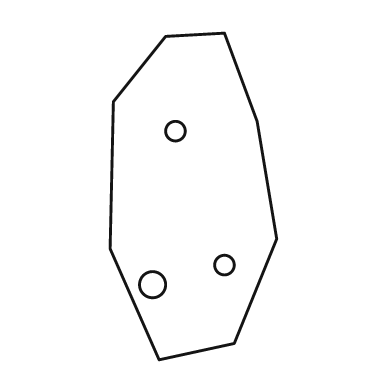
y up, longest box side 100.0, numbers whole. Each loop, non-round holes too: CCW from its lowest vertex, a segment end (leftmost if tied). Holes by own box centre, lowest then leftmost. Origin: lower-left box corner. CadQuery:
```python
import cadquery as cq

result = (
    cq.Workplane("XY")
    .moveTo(15.0, 0.0)
    .lineTo(38.0, 5.0)
    .lineTo(51.0, 37.0)
    .lineTo(45.0, 73.0)
    .lineTo(35.0, 100.0)
    .lineTo(17.0, 99.0)
    .lineTo(1.0, 79.0)
    .lineTo(0.0, 34.0)
    .close()
    .moveTo(13.0, 23.0)
    .circle(4.0)
    .moveTo(35.0, 29.0)
    .circle(3.0)
    .moveTo(20.0, 70.0)
    .circle(3.0)
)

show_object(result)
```